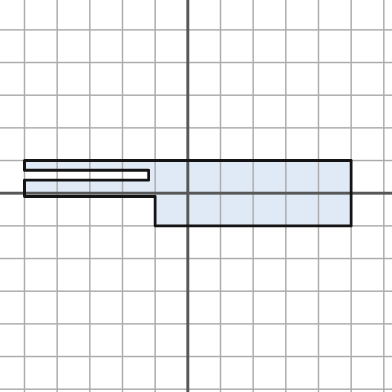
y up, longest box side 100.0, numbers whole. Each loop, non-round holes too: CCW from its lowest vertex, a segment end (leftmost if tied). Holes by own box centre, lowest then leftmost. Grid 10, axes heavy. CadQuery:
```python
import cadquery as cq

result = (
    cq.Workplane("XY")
    .moveTo(-10.0, -10.0)
    .lineTo(50.0, -10.0)
    .lineTo(50.0, 10.0)
    .lineTo(-50.0, 10.0)
    .lineTo(-50.0, 7.0)
    .lineTo(-12.0, 7.0)
    .lineTo(-12.0, 4.0)
    .lineTo(-50.0, 4.0)
    .lineTo(-50.0, -1.0)
    .lineTo(-10.0, -1.0)
    .close()
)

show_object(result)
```